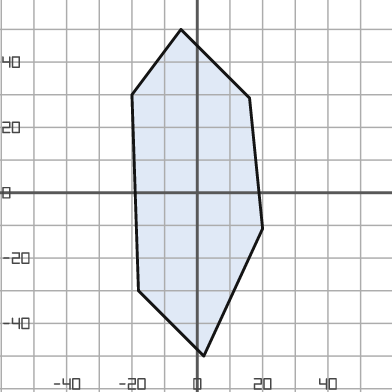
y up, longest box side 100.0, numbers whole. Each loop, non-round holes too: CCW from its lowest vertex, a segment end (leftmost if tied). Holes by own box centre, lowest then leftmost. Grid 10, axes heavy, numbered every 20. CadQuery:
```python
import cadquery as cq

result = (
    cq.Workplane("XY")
    .moveTo(2.0, -50.0)
    .lineTo(20.0, -11.0)
    .lineTo(16.0, 29.0)
    .lineTo(-5.0, 50.0)
    .lineTo(-20.0, 30.0)
    .lineTo(-18.0, -30.0)
    .close()
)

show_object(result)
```